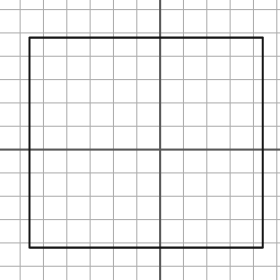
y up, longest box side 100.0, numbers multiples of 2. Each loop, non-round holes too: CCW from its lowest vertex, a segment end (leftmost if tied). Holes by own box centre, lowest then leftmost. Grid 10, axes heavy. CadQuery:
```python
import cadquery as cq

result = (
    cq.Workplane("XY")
    .moveTo(-56.0, -42.0)
    .lineTo(44.0, -42.0)
    .lineTo(44.0, 48.0)
    .lineTo(-56.0, 48.0)
    .close()
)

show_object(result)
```